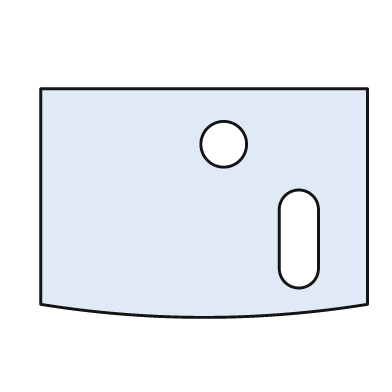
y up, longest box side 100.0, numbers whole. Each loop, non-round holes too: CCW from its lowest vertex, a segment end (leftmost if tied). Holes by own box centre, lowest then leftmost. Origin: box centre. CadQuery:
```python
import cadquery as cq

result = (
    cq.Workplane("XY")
    .moveTo(-50.0, -31.0)
    .threePointArc((0.0, -35.0), (50.0, -31.0))
    .lineTo(50.0, 35.0)
    .lineTo(-50.0, 35.0)
    .close()
    .moveTo(23.0, -20.0)
    .threePointArc((29.0, -26.0), (35.0, -20.0))
    .lineTo(35.0, -2.0)
    .threePointArc((29.0, 4.0), (23.0, -2.0))
    .close()
    .moveTo(6.0, 18.0)
    .circle(7.0)
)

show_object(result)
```